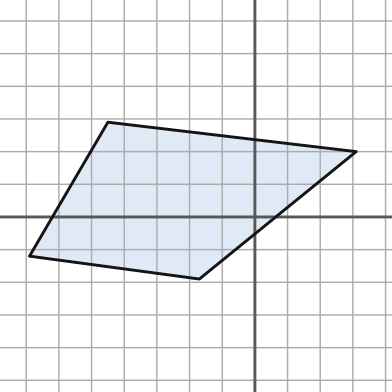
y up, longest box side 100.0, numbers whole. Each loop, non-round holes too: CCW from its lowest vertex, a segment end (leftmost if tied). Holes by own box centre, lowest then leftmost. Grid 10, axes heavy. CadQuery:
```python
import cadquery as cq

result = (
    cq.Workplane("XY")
    .moveTo(-17.0, -19.0)
    .lineTo(31.0, 20.0)
    .lineTo(-45.0, 29.0)
    .lineTo(-69.0, -12.0)
    .close()
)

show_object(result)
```